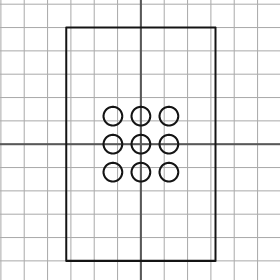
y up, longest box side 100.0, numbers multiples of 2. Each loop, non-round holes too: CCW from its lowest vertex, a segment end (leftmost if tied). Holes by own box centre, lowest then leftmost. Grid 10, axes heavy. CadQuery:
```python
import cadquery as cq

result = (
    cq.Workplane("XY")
    .moveTo(-32.0, -50.0)
    .lineTo(32.0, -50.0)
    .lineTo(32.0, 50.0)
    .lineTo(-32.0, 50.0)
    .close()
    .moveTo(-12.0, -12.0)
    .circle(4.0)
    .moveTo(0.0, -12.0)
    .circle(4.0)
    .moveTo(12.0, -12.0)
    .circle(4.0)
    .moveTo(-12.0, 0.0)
    .circle(4.0)
    .moveTo(0.0, 0.0)
    .circle(4.0)
    .moveTo(12.0, 0.0)
    .circle(4.0)
    .moveTo(-12.0, 12.0)
    .circle(4.0)
    .moveTo(0.0, 12.0)
    .circle(4.0)
    .moveTo(12.0, 12.0)
    .circle(4.0)
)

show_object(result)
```